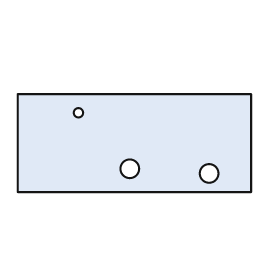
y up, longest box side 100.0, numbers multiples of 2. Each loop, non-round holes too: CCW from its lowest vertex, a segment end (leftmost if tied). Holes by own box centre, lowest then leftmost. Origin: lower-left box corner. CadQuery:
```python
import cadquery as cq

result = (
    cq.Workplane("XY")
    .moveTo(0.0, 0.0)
    .lineTo(100.0, 0.0)
    .lineTo(100.0, 42.0)
    .lineTo(0.0, 42.0)
    .close()
    .moveTo(82.0, 8.0)
    .circle(4.0)
    .moveTo(48.0, 10.0)
    .circle(4.0)
    .moveTo(26.0, 34.0)
    .circle(2.0)
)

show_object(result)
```